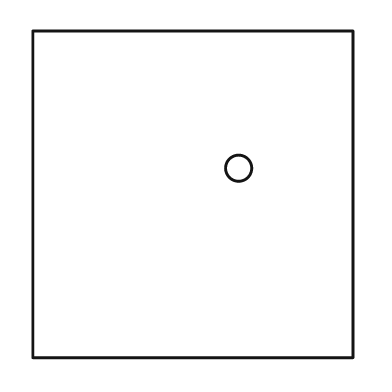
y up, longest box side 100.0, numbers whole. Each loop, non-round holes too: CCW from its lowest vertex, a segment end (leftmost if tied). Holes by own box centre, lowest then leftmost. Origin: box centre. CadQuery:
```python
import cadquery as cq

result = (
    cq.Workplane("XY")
    .moveTo(-49.0, -50.0)
    .lineTo(49.0, -50.0)
    .lineTo(49.0, 50.0)
    .lineTo(-49.0, 50.0)
    .close()
    .moveTo(14.0, 8.0)
    .circle(4.0)
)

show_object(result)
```